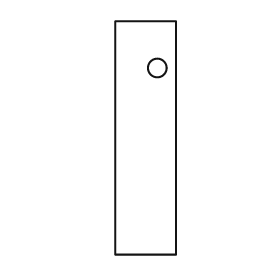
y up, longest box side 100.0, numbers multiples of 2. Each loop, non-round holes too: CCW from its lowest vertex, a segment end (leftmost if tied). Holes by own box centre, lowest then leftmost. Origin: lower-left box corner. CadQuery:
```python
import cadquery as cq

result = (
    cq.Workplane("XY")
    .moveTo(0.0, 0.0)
    .lineTo(26.0, 0.0)
    .lineTo(26.0, 100.0)
    .lineTo(0.0, 100.0)
    .close()
    .moveTo(18.0, 80.0)
    .circle(4.0)
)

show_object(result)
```